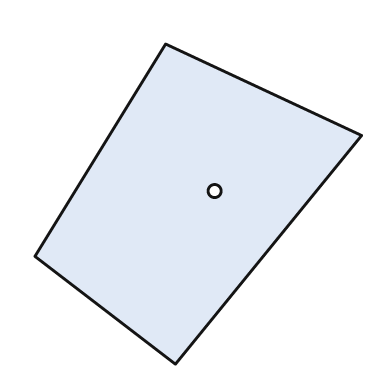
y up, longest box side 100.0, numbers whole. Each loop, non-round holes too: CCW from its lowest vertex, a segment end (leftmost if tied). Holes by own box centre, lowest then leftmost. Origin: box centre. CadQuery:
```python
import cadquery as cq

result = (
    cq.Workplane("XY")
    .moveTo(-7.0, -49.0)
    .lineTo(50.0, 21.0)
    .lineTo(-10.0, 49.0)
    .lineTo(-50.0, -16.0)
    .close()
    .moveTo(5.0, 4.0)
    .circle(2.0)
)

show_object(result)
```